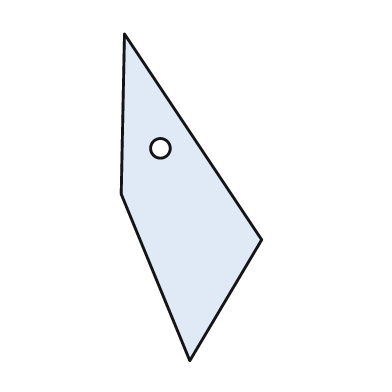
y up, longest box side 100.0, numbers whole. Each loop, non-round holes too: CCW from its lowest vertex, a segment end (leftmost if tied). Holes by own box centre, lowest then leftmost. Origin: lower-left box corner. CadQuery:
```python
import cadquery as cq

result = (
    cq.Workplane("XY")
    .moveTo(21.0, 0.0)
    .lineTo(43.0, 37.0)
    .lineTo(1.0, 100.0)
    .lineTo(0.0, 51.0)
    .close()
    .moveTo(12.0, 65.0)
    .circle(3.0)
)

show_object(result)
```